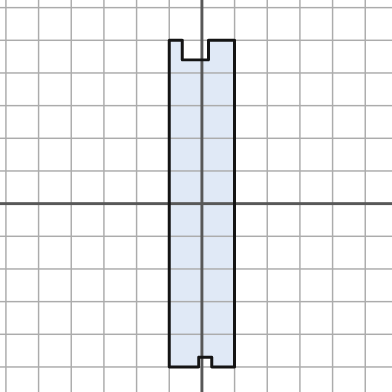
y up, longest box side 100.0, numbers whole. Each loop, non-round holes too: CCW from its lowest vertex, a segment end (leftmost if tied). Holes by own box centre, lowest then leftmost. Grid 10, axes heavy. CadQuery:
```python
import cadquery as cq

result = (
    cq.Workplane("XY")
    .moveTo(-10.0, -50.0)
    .lineTo(-1.0, -50.0)
    .lineTo(-1.0, -47.0)
    .lineTo(3.0, -47.0)
    .lineTo(3.0, -50.0)
    .lineTo(10.0, -50.0)
    .lineTo(10.0, 50.0)
    .lineTo(2.0, 50.0)
    .lineTo(2.0, 44.0)
    .lineTo(-6.0, 44.0)
    .lineTo(-6.0, 50.0)
    .lineTo(-10.0, 50.0)
    .close()
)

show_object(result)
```